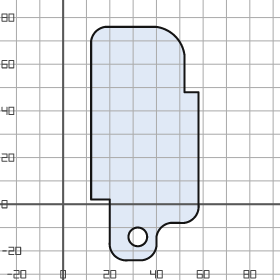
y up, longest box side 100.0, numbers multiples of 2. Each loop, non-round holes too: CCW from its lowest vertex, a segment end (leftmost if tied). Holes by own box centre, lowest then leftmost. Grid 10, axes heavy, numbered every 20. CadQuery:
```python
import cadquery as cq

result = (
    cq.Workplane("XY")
    .moveTo(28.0, -24.0)
    .lineTo(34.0, -24.0)
    .threePointArc((38.0, -22.0), (40.0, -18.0))
    .lineTo(40.0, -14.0)
    .threePointArc((42.0, -10.0), (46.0, -8.0))
    .lineTo(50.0, -8.0)
    .threePointArc((56.0, -6.0), (58.0, 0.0))
    .lineTo(58.0, 48.0)
    .lineTo(52.0, 48.0)
    .lineTo(52.0, 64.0)
    .threePointArc((48.0, 72.0), (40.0, 76.0))
    .lineTo(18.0, 76.0)
    .threePointArc((14.0, 74.0), (12.0, 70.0))
    .lineTo(12.0, 2.0)
    .lineTo(20.0, 2.0)
    .lineTo(20.0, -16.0)
    .threePointArc((22.0, -22.0), (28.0, -24.0))
    .close()
    .moveTo(32.0, -14.0)
    .circle(4.0)
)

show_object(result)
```